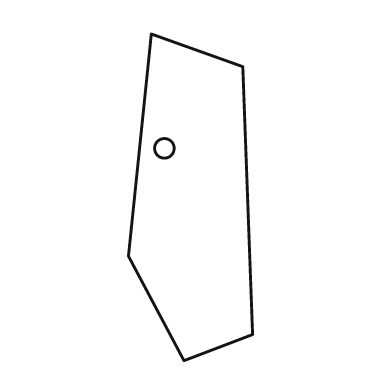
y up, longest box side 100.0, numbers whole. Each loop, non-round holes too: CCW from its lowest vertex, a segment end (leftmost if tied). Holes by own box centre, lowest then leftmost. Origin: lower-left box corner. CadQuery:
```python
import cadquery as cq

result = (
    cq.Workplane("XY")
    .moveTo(17.0, 0.0)
    .lineTo(38.0, 8.0)
    .lineTo(35.0, 90.0)
    .lineTo(7.0, 100.0)
    .lineTo(0.0, 32.0)
    .close()
    .moveTo(11.0, 65.0)
    .circle(3.0)
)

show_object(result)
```